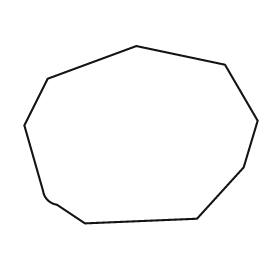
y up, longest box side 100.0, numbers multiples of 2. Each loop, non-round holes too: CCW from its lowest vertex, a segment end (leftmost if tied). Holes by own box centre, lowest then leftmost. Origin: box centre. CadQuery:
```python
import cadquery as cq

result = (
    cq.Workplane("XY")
    .moveTo(-24.0, -38.0)
    .lineTo(24.0, -36.0)
    .lineTo(44.0, -14.0)
    .lineTo(50.0, 6.0)
    .lineTo(36.0, 30.0)
    .lineTo(-2.0, 38.0)
    .lineTo(-40.0, 24.0)
    .lineTo(-50.0, 4.0)
    .lineTo(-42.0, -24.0)
    .threePointArc((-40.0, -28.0), (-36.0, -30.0))
    .close()
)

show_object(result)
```